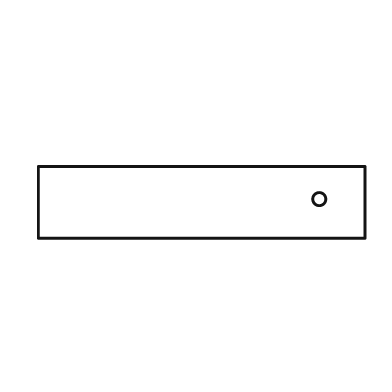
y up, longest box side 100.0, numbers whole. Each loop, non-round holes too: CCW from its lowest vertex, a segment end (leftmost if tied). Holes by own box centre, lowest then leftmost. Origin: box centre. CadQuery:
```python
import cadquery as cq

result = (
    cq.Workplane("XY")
    .moveTo(-50.0, -11.0)
    .lineTo(50.0, -11.0)
    .lineTo(50.0, 11.0)
    .lineTo(-50.0, 11.0)
    .close()
    .moveTo(36.0, 1.0)
    .circle(2.0)
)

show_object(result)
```